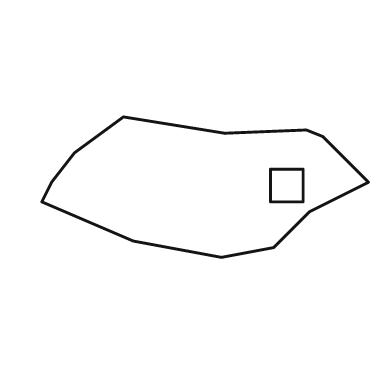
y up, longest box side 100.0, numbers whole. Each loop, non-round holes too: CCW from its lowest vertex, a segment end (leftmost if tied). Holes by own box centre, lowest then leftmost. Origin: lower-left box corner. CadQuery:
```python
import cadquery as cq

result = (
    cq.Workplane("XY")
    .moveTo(55.0, 0.0)
    .lineTo(71.0, 3.0)
    .lineTo(82.0, 14.0)
    .lineTo(100.0, 23.0)
    .lineTo(86.0, 37.0)
    .lineTo(81.0, 39.0)
    .lineTo(56.0, 38.0)
    .lineTo(25.0, 43.0)
    .lineTo(10.0, 32.0)
    .lineTo(3.0, 23.0)
    .lineTo(0.0, 17.0)
    .lineTo(28.0, 5.0)
    .close()
    .moveTo(70.0, 17.0)
    .lineTo(80.0, 17.0)
    .lineTo(80.0, 27.0)
    .lineTo(70.0, 27.0)
    .close()
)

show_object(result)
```